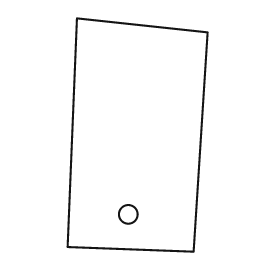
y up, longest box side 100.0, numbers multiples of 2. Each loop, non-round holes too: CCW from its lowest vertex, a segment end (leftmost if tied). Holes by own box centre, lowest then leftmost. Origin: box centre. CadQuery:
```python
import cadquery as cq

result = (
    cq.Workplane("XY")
    .moveTo(24.0, -50.0)
    .lineTo(30.0, 44.0)
    .lineTo(-26.0, 50.0)
    .lineTo(-30.0, -48.0)
    .close()
    .moveTo(-4.0, -34.0)
    .circle(4.0)
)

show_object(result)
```